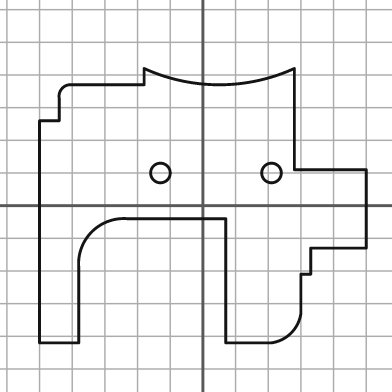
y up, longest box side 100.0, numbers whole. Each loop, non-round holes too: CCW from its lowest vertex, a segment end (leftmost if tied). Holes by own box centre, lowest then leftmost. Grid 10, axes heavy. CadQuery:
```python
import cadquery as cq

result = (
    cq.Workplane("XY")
    .moveTo(-50.0, -42.0)
    .lineTo(-38.0, -42.0)
    .lineTo(-38.0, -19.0)
    .threePointArc((-34.0, -8.0), (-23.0, -4.0))
    .lineTo(7.0, -4.0)
    .lineTo(7.0, -42.0)
    .lineTo(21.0, -42.0)
    .threePointArc((27.0, -39.0), (30.0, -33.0))
    .lineTo(30.0, -21.0)
    .lineTo(33.0, -21.0)
    .lineTo(33.0, -13.0)
    .lineTo(50.0, -13.0)
    .lineTo(50.0, 11.0)
    .lineTo(28.0, 11.0)
    .lineTo(28.0, 42.0)
    .threePointArc((5.0, 37.0), (-18.0, 42.0))
    .lineTo(-18.0, 37.0)
    .lineTo(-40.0, 37.0)
    .threePointArc((-43.0, 36.0), (-44.0, 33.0))
    .lineTo(-44.0, 26.0)
    .lineTo(-50.0, 26.0)
    .close()
    .moveTo(-13.0, 10.0)
    .circle(3.0)
    .moveTo(21.0, 10.0)
    .circle(3.0)
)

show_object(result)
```